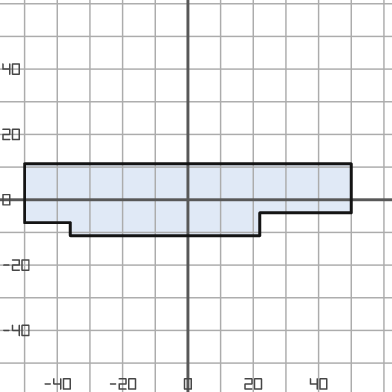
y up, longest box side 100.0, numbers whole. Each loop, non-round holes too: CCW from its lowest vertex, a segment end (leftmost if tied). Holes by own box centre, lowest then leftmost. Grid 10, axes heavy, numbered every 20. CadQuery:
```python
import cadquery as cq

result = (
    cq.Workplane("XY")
    .moveTo(-36.0, -11.0)
    .lineTo(22.0, -11.0)
    .lineTo(22.0, -4.0)
    .lineTo(50.0, -4.0)
    .lineTo(50.0, 11.0)
    .lineTo(-50.0, 11.0)
    .lineTo(-50.0, -7.0)
    .lineTo(-36.0, -7.0)
    .close()
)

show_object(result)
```